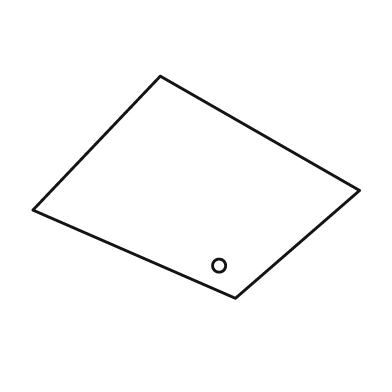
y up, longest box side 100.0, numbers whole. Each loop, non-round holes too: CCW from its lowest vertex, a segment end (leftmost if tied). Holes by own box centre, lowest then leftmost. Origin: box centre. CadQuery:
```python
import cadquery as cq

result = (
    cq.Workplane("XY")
    .moveTo(12.0, -34.0)
    .lineTo(50.0, -1.0)
    .lineTo(-11.0, 34.0)
    .lineTo(-50.0, -7.0)
    .close()
    .moveTo(7.0, -24.0)
    .circle(2.0)
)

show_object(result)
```